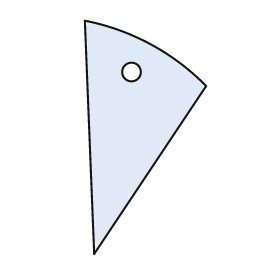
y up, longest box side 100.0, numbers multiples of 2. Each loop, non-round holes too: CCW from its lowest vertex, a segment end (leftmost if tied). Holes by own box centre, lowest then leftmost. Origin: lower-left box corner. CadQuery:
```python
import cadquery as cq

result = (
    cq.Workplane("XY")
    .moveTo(4.0, 0.0)
    .lineTo(52.0, 72.0)
    .threePointArc((28.0, 90.0), (0.0, 100.0))
    .close()
    .moveTo(20.0, 78.0)
    .circle(4.0)
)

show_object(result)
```